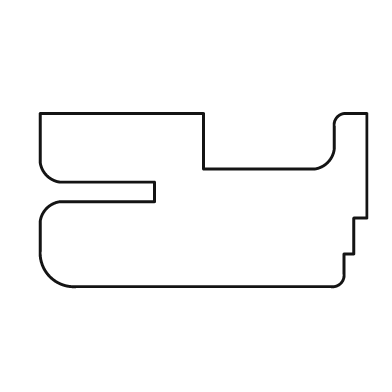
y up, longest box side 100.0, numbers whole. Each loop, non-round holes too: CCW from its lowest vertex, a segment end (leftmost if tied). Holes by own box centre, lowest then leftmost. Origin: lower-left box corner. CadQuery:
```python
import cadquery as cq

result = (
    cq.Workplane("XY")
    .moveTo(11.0, 0.0)
    .lineTo(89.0, 0.0)
    .threePointArc((92.0, 1.0), (93.0, 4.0))
    .lineTo(93.0, 10.0)
    .lineTo(96.0, 10.0)
    .lineTo(96.0, 21.0)
    .lineTo(100.0, 21.0)
    .lineTo(100.0, 53.0)
    .lineTo(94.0, 53.0)
    .threePointArc((91.0, 52.0), (90.0, 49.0))
    .lineTo(90.0, 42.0)
    .threePointArc((88.0, 38.0), (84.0, 36.0))
    .lineTo(50.0, 36.0)
    .lineTo(50.0, 53.0)
    .lineTo(0.0, 53.0)
    .lineTo(0.0, 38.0)
    .threePointArc((2.0, 34.0), (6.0, 32.0))
    .lineTo(35.0, 32.0)
    .lineTo(35.0, 26.0)
    .lineTo(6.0, 26.0)
    .threePointArc((2.0, 24.0), (0.0, 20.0))
    .lineTo(0.0, 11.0)
    .threePointArc((3.0, 3.0), (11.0, 0.0))
    .close()
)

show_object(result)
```